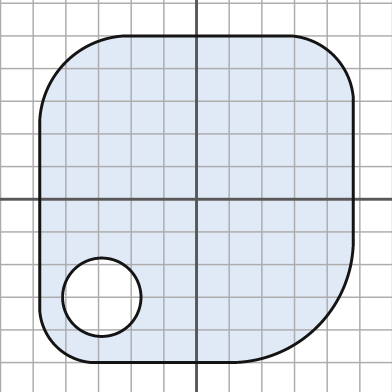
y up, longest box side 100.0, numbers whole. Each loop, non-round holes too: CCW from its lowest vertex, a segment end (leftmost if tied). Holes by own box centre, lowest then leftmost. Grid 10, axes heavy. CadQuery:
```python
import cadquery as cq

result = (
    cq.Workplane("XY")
    .moveTo(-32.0, -50.0)
    .lineTo(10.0, -50.0)
    .threePointArc((37.0, -39.0), (48.0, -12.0))
    .lineTo(48.0, 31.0)
    .threePointArc((42.0, 44.0), (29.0, 50.0))
    .lineTo(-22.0, 50.0)
    .threePointArc((-40.0, 42.0), (-48.0, 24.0))
    .lineTo(-48.0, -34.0)
    .threePointArc((-43.0, -45.0), (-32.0, -50.0))
    .close()
    .moveTo(-29.0, -30.0)
    .circle(12.0)
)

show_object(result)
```